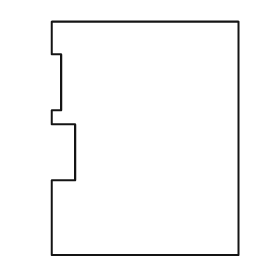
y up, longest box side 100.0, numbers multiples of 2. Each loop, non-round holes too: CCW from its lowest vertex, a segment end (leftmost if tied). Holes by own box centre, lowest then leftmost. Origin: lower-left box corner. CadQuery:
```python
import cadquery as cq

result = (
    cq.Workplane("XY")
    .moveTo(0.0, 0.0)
    .lineTo(80.0, 0.0)
    .lineTo(80.0, 100.0)
    .lineTo(0.0, 100.0)
    .lineTo(0.0, 86.0)
    .lineTo(4.0, 86.0)
    .lineTo(4.0, 62.0)
    .lineTo(0.0, 62.0)
    .lineTo(0.0, 56.0)
    .lineTo(10.0, 56.0)
    .lineTo(10.0, 32.0)
    .lineTo(0.0, 32.0)
    .close()
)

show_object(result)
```